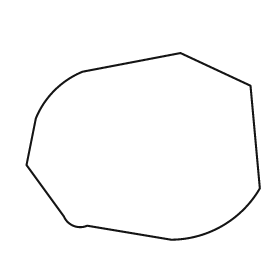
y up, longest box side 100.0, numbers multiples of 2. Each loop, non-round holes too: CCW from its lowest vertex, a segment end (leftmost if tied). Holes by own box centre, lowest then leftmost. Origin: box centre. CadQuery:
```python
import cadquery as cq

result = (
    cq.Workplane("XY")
    .moveTo(12.0, -40.0)
    .threePointArc((34.0, -34.0), (50.0, -18.0))
    .lineTo(46.0, 26.0)
    .lineTo(16.0, 40.0)
    .lineTo(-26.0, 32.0)
    .threePointArc((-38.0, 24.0), (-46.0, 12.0))
    .lineTo(-50.0, -8.0)
    .lineTo(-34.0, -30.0)
    .threePointArc((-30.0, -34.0), (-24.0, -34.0))
    .close()
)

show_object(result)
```